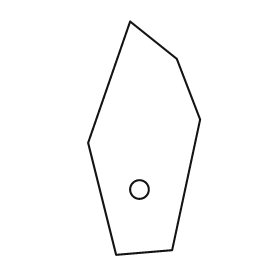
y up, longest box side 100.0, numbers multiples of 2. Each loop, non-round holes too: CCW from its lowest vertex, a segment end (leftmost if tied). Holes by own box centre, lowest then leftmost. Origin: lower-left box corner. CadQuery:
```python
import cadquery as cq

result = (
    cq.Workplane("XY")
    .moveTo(12.0, 0.0)
    .lineTo(36.0, 2.0)
    .lineTo(48.0, 58.0)
    .lineTo(38.0, 84.0)
    .lineTo(18.0, 100.0)
    .lineTo(0.0, 48.0)
    .close()
    .moveTo(22.0, 28.0)
    .circle(4.0)
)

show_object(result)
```